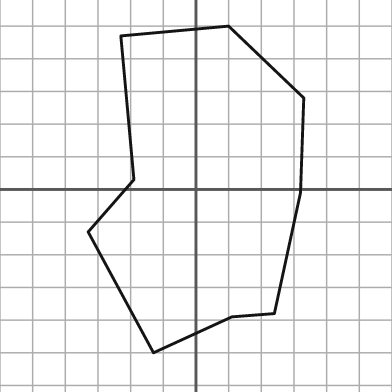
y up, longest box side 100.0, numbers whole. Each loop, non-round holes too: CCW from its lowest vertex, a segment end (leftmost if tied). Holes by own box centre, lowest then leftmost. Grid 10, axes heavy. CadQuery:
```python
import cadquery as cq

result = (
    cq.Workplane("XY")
    .moveTo(-13.0, -50.0)
    .lineTo(11.0, -39.0)
    .lineTo(24.0, -38.0)
    .lineTo(32.0, -1.0)
    .lineTo(33.0, 28.0)
    .lineTo(10.0, 50.0)
    .lineTo(-23.0, 47.0)
    .lineTo(-19.0, 3.0)
    .lineTo(-33.0, -13.0)
    .close()
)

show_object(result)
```